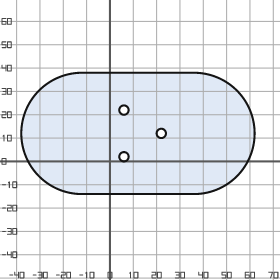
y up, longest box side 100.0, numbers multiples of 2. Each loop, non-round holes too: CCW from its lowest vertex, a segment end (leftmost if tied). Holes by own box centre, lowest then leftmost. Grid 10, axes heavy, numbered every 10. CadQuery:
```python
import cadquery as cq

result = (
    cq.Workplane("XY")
    .moveTo(-12.0, -14.0)
    .lineTo(36.0, -14.0)
    .threePointArc((62.0, 12.0), (36.0, 38.0))
    .lineTo(-12.0, 38.0)
    .threePointArc((-38.0, 12.0), (-12.0, -14.0))
    .close()
    .moveTo(6.0, 2.0)
    .circle(2.0)
    .moveTo(22.0, 12.0)
    .circle(2.0)
    .moveTo(6.0, 22.0)
    .circle(2.0)
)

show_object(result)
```